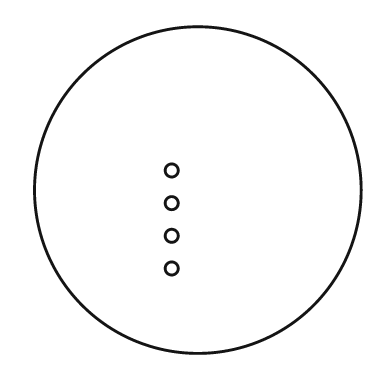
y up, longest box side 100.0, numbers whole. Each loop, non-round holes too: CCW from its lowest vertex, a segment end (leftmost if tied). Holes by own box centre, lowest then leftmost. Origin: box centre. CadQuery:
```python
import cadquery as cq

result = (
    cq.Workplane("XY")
    .moveTo(0.0, 0.0)
    .circle(50.0)
    .moveTo(-8.0, -24.0)
    .circle(2.0)
    .moveTo(-8.0, -14.0)
    .circle(2.0)
    .moveTo(-8.0, -4.0)
    .circle(2.0)
    .moveTo(-8.0, 6.0)
    .circle(2.0)
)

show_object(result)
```